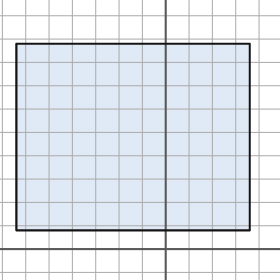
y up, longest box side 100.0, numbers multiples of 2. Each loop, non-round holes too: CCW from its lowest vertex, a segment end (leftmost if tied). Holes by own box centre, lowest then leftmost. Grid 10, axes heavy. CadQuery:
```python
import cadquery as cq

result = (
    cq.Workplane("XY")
    .moveTo(-64.0, 8.0)
    .lineTo(36.0, 8.0)
    .lineTo(36.0, 88.0)
    .lineTo(-64.0, 88.0)
    .close()
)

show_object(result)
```